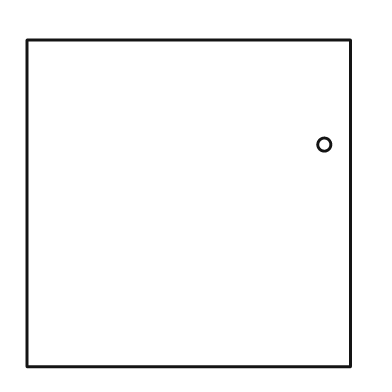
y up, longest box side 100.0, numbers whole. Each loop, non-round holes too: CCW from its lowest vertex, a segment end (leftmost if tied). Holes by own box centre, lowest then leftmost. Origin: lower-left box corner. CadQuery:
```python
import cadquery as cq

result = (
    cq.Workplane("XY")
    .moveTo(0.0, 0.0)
    .lineTo(99.0, 0.0)
    .lineTo(99.0, 100.0)
    .lineTo(0.0, 100.0)
    .close()
    .moveTo(91.0, 68.0)
    .circle(2.0)
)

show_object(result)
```